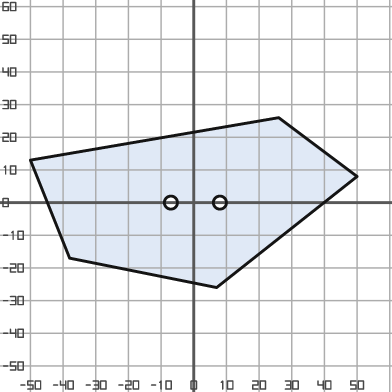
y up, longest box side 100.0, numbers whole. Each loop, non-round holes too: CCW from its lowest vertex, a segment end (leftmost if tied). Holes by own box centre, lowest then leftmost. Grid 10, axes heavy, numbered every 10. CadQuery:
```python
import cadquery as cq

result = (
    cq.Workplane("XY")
    .moveTo(7.0, -26.0)
    .lineTo(50.0, 8.0)
    .lineTo(26.0, 26.0)
    .lineTo(-50.0, 13.0)
    .lineTo(-38.0, -17.0)
    .close()
    .moveTo(-7.0, 0.0)
    .circle(2.0)
    .moveTo(8.0, 0.0)
    .circle(2.0)
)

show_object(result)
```